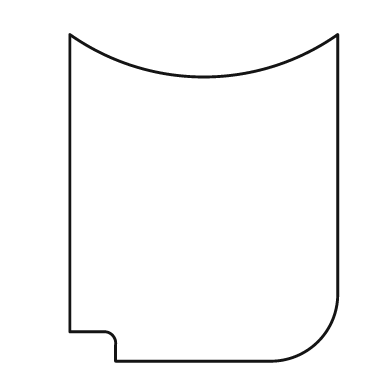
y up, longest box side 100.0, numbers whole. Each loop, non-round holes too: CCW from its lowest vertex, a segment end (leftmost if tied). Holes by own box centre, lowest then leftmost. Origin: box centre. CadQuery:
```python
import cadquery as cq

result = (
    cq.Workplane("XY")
    .moveTo(-27.0, -50.0)
    .lineTo(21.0, -50.0)
    .threePointArc((35.0, -44.0), (41.0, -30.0))
    .lineTo(41.0, 50.0)
    .threePointArc((0.0, 37.0), (-41.0, 50.0))
    .lineTo(-41.0, -41.0)
    .lineTo(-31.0, -41.0)
    .threePointArc((-28.0, -42.0), (-27.0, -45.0))
    .close()
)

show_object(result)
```